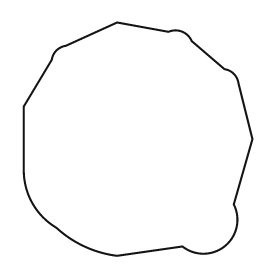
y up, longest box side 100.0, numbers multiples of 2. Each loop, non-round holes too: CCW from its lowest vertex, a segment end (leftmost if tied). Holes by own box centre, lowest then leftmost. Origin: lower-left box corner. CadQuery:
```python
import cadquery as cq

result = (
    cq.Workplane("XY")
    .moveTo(40.0, 0.0)
    .lineTo(68.0, 4.0)
    .threePointArc((86.0, 4.0), (90.0, 22.0))
    .lineTo(98.0, 50.0)
    .lineTo(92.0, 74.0)
    .threePointArc((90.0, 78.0), (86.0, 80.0))
    .lineTo(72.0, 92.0)
    .threePointArc((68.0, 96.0), (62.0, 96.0))
    .lineTo(40.0, 100.0)
    .lineTo(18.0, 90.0)
    .threePointArc((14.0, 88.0), (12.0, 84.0))
    .lineTo(0.0, 64.0)
    .lineTo(0.0, 36.0)
    .threePointArc((4.0, 22.0), (14.0, 12.0))
    .threePointArc((26.0, 4.0), (40.0, 0.0))
    .close()
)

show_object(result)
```